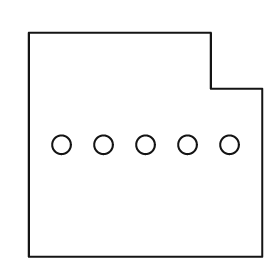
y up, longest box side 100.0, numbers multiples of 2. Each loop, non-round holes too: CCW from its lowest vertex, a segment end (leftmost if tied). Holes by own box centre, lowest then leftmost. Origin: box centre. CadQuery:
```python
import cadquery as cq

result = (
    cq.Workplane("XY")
    .moveTo(-50.0, -48.0)
    .lineTo(50.0, -48.0)
    .lineTo(50.0, 24.0)
    .lineTo(28.0, 24.0)
    .lineTo(28.0, 48.0)
    .lineTo(-50.0, 48.0)
    .close()
    .moveTo(-36.0, 0.0)
    .circle(4.0)
    .moveTo(-18.0, 0.0)
    .circle(4.0)
    .moveTo(0.0, 0.0)
    .circle(4.0)
    .moveTo(18.0, 0.0)
    .circle(4.0)
    .moveTo(36.0, 0.0)
    .circle(4.0)
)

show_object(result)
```